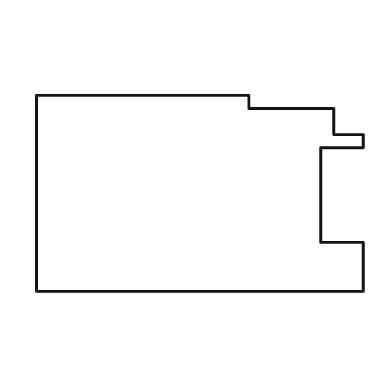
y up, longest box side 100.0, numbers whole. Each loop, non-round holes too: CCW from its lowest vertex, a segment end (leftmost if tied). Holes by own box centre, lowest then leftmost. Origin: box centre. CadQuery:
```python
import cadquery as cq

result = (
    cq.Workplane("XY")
    .moveTo(-50.0, -30.0)
    .lineTo(50.0, -30.0)
    .lineTo(50.0, -15.0)
    .lineTo(37.0, -15.0)
    .lineTo(37.0, 14.0)
    .lineTo(50.0, 14.0)
    .lineTo(50.0, 18.0)
    .lineTo(41.0, 18.0)
    .lineTo(41.0, 26.0)
    .lineTo(15.0, 26.0)
    .lineTo(15.0, 30.0)
    .lineTo(-50.0, 30.0)
    .close()
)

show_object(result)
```